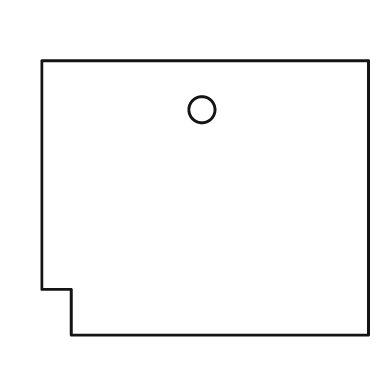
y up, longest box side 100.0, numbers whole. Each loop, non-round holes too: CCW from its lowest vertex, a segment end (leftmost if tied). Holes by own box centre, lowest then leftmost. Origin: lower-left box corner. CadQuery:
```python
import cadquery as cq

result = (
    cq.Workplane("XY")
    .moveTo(9.0, 0.0)
    .lineTo(100.0, 0.0)
    .lineTo(100.0, 84.0)
    .lineTo(0.0, 84.0)
    .lineTo(0.0, 14.0)
    .lineTo(9.0, 14.0)
    .close()
    .moveTo(49.0, 69.0)
    .circle(4.0)
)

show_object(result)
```